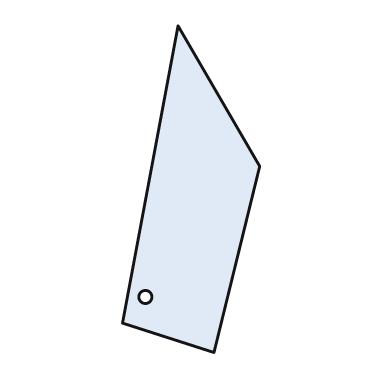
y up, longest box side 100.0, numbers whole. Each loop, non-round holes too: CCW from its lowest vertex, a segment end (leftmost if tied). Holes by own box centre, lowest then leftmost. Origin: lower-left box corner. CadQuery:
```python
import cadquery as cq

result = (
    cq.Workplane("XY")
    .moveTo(28.0, 0.0)
    .lineTo(42.0, 57.0)
    .lineTo(17.0, 100.0)
    .lineTo(0.0, 9.0)
    .close()
    .moveTo(7.0, 17.0)
    .circle(2.0)
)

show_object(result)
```